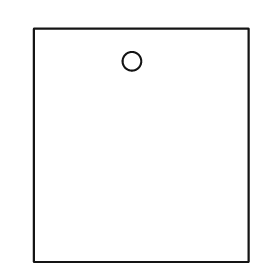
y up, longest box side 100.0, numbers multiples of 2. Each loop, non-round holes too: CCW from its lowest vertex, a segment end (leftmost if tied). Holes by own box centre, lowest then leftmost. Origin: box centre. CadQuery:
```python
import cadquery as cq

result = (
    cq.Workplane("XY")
    .moveTo(-46.0, -50.0)
    .lineTo(46.0, -50.0)
    .lineTo(46.0, 50.0)
    .lineTo(-46.0, 50.0)
    .close()
    .moveTo(-4.0, 36.0)
    .circle(4.0)
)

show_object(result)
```